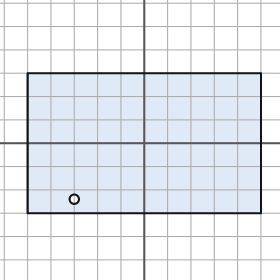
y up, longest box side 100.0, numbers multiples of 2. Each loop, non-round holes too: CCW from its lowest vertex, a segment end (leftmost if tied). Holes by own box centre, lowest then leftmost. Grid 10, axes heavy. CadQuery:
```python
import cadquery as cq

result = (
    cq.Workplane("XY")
    .moveTo(-50.0, -30.0)
    .lineTo(50.0, -30.0)
    .lineTo(50.0, 30.0)
    .lineTo(-50.0, 30.0)
    .close()
    .moveTo(-30.0, -24.0)
    .circle(2.0)
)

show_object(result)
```